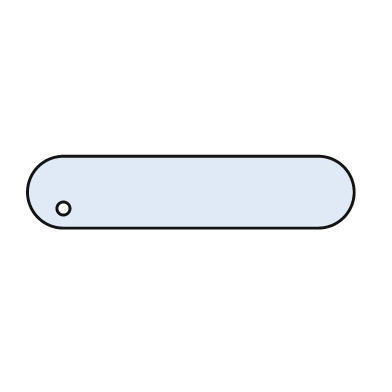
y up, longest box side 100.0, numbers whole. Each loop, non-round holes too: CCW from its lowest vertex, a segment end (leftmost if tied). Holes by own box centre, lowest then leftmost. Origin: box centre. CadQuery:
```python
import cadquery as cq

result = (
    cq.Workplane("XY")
    .moveTo(-39.0, -11.0)
    .lineTo(39.0, -11.0)
    .threePointArc((50.0, 0.0), (39.0, 11.0))
    .lineTo(-39.0, 11.0)
    .threePointArc((-50.0, 0.0), (-39.0, -11.0))
    .close()
    .moveTo(-39.0, -5.0)
    .circle(2.0)
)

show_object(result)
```